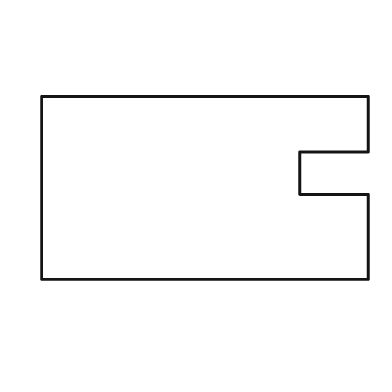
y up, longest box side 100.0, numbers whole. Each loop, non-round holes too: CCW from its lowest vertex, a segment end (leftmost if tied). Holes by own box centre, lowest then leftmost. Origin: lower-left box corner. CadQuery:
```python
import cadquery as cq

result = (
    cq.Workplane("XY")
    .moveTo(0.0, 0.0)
    .lineTo(100.0, 0.0)
    .lineTo(100.0, 26.0)
    .lineTo(79.0, 26.0)
    .lineTo(79.0, 39.0)
    .lineTo(100.0, 39.0)
    .lineTo(100.0, 56.0)
    .lineTo(0.0, 56.0)
    .close()
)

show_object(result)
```